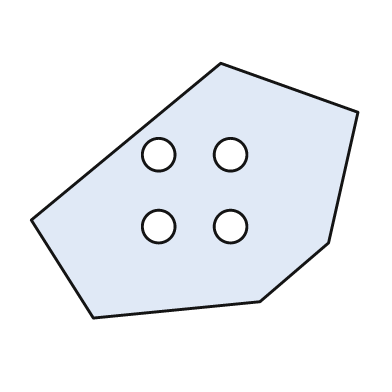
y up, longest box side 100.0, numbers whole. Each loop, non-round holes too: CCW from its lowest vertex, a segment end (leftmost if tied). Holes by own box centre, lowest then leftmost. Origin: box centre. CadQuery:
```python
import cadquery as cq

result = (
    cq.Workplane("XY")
    .moveTo(-31.0, -39.0)
    .lineTo(20.0, -34.0)
    .lineTo(41.0, -16.0)
    .lineTo(50.0, 24.0)
    .lineTo(8.0, 39.0)
    .lineTo(-50.0, -9.0)
    .close()
    .moveTo(-11.0, -11.0)
    .circle(5.0)
    .moveTo(11.0, -11.0)
    .circle(5.0)
    .moveTo(-11.0, 11.0)
    .circle(5.0)
    .moveTo(11.0, 11.0)
    .circle(5.0)
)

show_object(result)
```